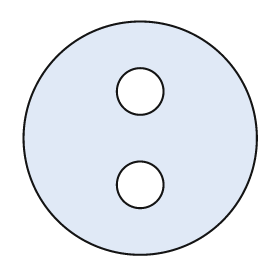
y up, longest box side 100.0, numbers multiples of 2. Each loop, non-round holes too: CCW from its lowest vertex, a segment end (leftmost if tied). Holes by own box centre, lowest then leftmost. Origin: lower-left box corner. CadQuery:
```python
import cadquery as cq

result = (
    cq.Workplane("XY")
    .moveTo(50.0, 50.0)
    .circle(50.0)
    .moveTo(50.0, 30.0)
    .circle(10.0)
    .moveTo(50.0, 70.0)
    .circle(10.0)
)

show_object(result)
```